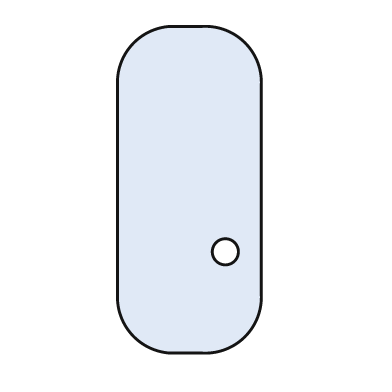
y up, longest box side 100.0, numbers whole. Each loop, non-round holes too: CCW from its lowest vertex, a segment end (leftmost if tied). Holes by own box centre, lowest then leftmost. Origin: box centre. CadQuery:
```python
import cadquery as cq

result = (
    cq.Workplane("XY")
    .moveTo(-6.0, -50.0)
    .lineTo(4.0, -50.0)
    .threePointArc((17.0, -45.0), (22.0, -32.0))
    .lineTo(22.0, 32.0)
    .threePointArc((17.0, 45.0), (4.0, 50.0))
    .lineTo(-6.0, 50.0)
    .threePointArc((-17.0, 45.0), (-22.0, 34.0))
    .lineTo(-22.0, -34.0)
    .threePointArc((-17.0, -45.0), (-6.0, -50.0))
    .close()
    .moveTo(11.0, -19.0)
    .circle(4.0)
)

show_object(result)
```